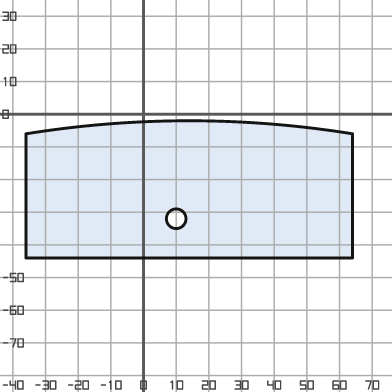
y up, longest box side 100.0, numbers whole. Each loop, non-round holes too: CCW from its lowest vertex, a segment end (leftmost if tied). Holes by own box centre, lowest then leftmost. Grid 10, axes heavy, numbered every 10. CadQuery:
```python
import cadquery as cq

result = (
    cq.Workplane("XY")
    .moveTo(-36.0, -44.0)
    .lineTo(64.0, -44.0)
    .lineTo(64.0, -6.0)
    .threePointArc((14.0, -2.0), (-36.0, -6.0))
    .close()
    .moveTo(10.0, -32.0)
    .circle(3.0)
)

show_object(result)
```